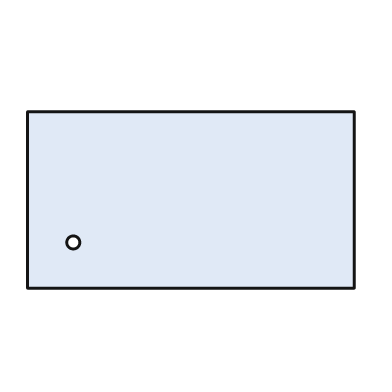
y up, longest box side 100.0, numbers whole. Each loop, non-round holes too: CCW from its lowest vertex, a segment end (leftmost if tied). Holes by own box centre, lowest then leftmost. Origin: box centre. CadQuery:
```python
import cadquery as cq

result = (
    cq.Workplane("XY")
    .moveTo(-50.0, -27.0)
    .lineTo(50.0, -27.0)
    .lineTo(50.0, 27.0)
    .lineTo(-50.0, 27.0)
    .close()
    .moveTo(-36.0, -13.0)
    .circle(2.0)
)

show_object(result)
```